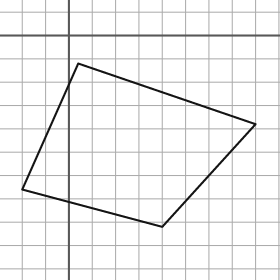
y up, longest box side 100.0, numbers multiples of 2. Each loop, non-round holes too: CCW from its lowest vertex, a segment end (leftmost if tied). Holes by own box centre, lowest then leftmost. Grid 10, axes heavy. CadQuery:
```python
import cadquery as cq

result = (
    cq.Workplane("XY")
    .moveTo(40.0, -82.0)
    .lineTo(80.0, -38.0)
    .lineTo(4.0, -12.0)
    .lineTo(-20.0, -66.0)
    .close()
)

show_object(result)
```